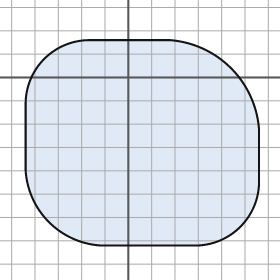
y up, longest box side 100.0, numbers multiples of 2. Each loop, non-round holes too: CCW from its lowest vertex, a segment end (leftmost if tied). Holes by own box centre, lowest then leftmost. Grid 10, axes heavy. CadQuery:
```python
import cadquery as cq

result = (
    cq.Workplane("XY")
    .moveTo(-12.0, -72.0)
    .lineTo(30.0, -72.0)
    .threePointArc((48.0, -64.0), (56.0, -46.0))
    .lineTo(56.0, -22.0)
    .threePointArc((44.0, 4.0), (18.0, 16.0))
    .lineTo(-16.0, 16.0)
    .threePointArc((-36.0, 8.0), (-44.0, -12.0))
    .lineTo(-44.0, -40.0)
    .threePointArc((-34.0, -62.0), (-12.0, -72.0))
    .close()
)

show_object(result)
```